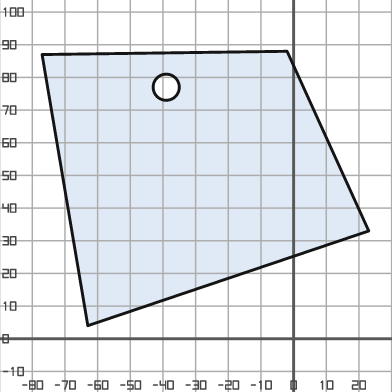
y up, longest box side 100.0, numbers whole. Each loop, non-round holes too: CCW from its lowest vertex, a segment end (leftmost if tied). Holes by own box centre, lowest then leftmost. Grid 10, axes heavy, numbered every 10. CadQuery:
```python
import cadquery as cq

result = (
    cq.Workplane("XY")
    .moveTo(-63.0, 4.0)
    .lineTo(23.0, 33.0)
    .lineTo(-2.0, 88.0)
    .lineTo(-77.0, 87.0)
    .close()
    .moveTo(-39.0, 77.0)
    .circle(4.0)
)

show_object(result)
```